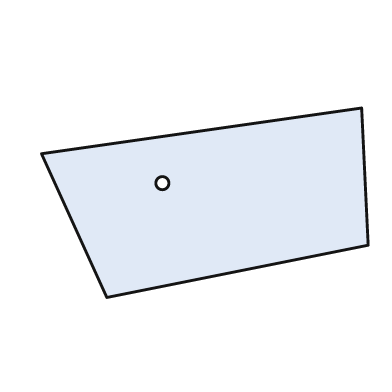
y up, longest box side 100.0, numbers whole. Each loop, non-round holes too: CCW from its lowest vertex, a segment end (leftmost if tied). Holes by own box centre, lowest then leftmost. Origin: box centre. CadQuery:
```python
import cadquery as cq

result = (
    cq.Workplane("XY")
    .moveTo(-30.0, -29.0)
    .lineTo(50.0, -13.0)
    .lineTo(48.0, 29.0)
    .lineTo(-50.0, 15.0)
    .close()
    .moveTo(-13.0, 6.0)
    .circle(2.0)
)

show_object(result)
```